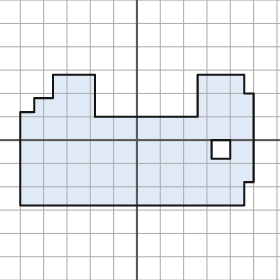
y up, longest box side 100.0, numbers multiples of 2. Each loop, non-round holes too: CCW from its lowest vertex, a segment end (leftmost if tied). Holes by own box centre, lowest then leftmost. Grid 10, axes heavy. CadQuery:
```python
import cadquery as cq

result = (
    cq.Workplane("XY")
    .moveTo(-50.0, -28.0)
    .lineTo(46.0, -28.0)
    .lineTo(46.0, -18.0)
    .lineTo(50.0, -18.0)
    .lineTo(50.0, 20.0)
    .lineTo(46.0, 20.0)
    .lineTo(46.0, 28.0)
    .lineTo(26.0, 28.0)
    .lineTo(26.0, 10.0)
    .lineTo(-18.0, 10.0)
    .lineTo(-18.0, 28.0)
    .lineTo(-36.0, 28.0)
    .lineTo(-36.0, 18.0)
    .lineTo(-44.0, 18.0)
    .lineTo(-44.0, 12.0)
    .lineTo(-50.0, 12.0)
    .close()
    .moveTo(32.0, -8.0)
    .lineTo(40.0, -8.0)
    .lineTo(40.0, 0.0)
    .lineTo(32.0, 0.0)
    .close()
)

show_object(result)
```